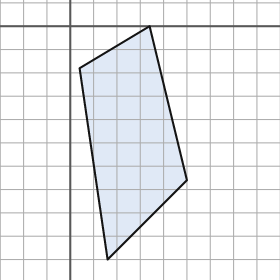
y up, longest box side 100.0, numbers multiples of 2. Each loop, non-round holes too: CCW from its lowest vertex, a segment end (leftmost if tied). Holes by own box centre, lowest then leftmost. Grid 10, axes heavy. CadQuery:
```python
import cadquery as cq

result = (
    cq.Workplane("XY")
    .moveTo(16.0, -100.0)
    .lineTo(50.0, -66.0)
    .lineTo(34.0, 0.0)
    .lineTo(4.0, -18.0)
    .close()
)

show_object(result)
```